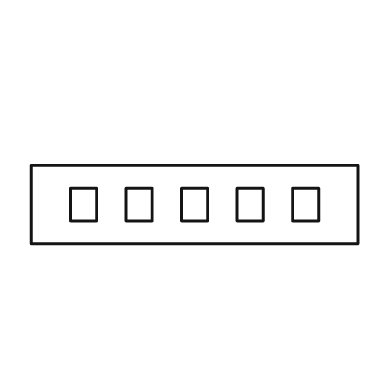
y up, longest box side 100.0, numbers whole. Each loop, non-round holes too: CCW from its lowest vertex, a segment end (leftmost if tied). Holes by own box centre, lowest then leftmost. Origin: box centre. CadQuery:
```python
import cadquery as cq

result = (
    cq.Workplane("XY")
    .moveTo(-50.0, -12.0)
    .lineTo(50.0, -12.0)
    .lineTo(50.0, 12.0)
    .lineTo(-50.0, 12.0)
    .close()
    .moveTo(-38.0, -5.0)
    .lineTo(-30.0, -5.0)
    .lineTo(-30.0, 5.0)
    .lineTo(-38.0, 5.0)
    .close()
    .moveTo(-21.0, -5.0)
    .lineTo(-13.0, -5.0)
    .lineTo(-13.0, 5.0)
    .lineTo(-21.0, 5.0)
    .close()
    .moveTo(-4.0, -5.0)
    .lineTo(4.0, -5.0)
    .lineTo(4.0, 5.0)
    .lineTo(-4.0, 5.0)
    .close()
    .moveTo(13.0, -5.0)
    .lineTo(21.0, -5.0)
    .lineTo(21.0, 5.0)
    .lineTo(13.0, 5.0)
    .close()
    .moveTo(30.0, -5.0)
    .lineTo(38.0, -5.0)
    .lineTo(38.0, 5.0)
    .lineTo(30.0, 5.0)
    .close()
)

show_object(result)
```